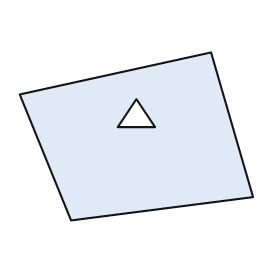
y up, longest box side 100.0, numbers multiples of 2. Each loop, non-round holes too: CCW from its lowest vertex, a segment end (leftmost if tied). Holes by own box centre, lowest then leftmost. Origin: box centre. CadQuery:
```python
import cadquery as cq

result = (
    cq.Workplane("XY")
    .moveTo(-28.0, -36.0)
    .lineTo(50.0, -26.0)
    .lineTo(32.0, 36.0)
    .lineTo(-50.0, 18.0)
    .close()
    .moveTo(-8.0, 4.0)
    .lineTo(8.0, 4.0)
    .lineTo(0.0, 16.0)
    .close()
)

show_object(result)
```